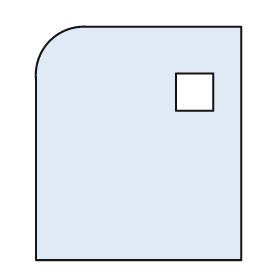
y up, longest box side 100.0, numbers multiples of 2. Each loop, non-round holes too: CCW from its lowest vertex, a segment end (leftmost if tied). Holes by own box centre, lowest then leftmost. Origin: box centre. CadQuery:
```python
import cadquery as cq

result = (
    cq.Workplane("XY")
    .moveTo(-44.0, -50.0)
    .lineTo(44.0, -50.0)
    .lineTo(44.0, 50.0)
    .lineTo(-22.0, 50.0)
    .threePointArc((-38.0, 44.0), (-44.0, 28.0))
    .close()
    .moveTo(16.0, 14.0)
    .lineTo(32.0, 14.0)
    .lineTo(32.0, 30.0)
    .lineTo(16.0, 30.0)
    .close()
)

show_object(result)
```